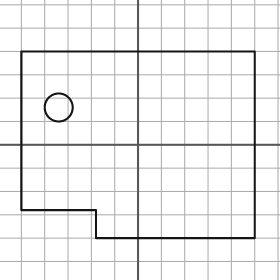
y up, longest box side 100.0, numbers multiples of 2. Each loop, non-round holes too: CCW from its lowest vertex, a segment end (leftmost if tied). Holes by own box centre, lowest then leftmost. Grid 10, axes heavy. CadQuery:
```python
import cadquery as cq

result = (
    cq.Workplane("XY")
    .moveTo(-18.0, -40.0)
    .lineTo(50.0, -40.0)
    .lineTo(50.0, 40.0)
    .lineTo(-50.0, 40.0)
    .lineTo(-50.0, -28.0)
    .lineTo(-18.0, -28.0)
    .close()
    .moveTo(-34.0, 16.0)
    .circle(6.0)
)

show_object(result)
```